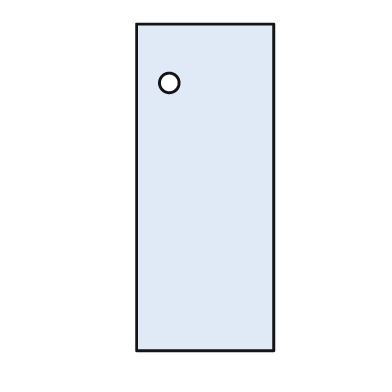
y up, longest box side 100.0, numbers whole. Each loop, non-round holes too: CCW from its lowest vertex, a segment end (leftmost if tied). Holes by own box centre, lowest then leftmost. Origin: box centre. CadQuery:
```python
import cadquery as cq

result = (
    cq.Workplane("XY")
    .moveTo(-21.0, -50.0)
    .lineTo(21.0, -50.0)
    .lineTo(21.0, 50.0)
    .lineTo(-21.0, 50.0)
    .close()
    .moveTo(-11.0, 32.0)
    .circle(3.0)
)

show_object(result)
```